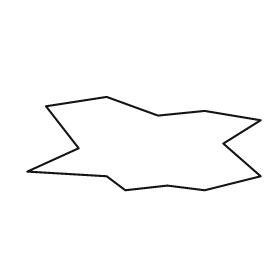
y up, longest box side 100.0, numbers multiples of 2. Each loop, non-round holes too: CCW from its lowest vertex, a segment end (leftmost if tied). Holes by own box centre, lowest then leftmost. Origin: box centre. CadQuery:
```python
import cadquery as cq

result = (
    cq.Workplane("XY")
    .moveTo(-8.0, -20.0)
    .lineTo(10.0, -18.0)
    .lineTo(26.0, -20.0)
    .lineTo(50.0, -14.0)
    .lineTo(34.0, 0.0)
    .lineTo(50.0, 10.0)
    .lineTo(26.0, 14.0)
    .lineTo(6.0, 12.0)
    .lineTo(-16.0, 20.0)
    .lineTo(-42.0, 16.0)
    .lineTo(-28.0, -2.0)
    .lineTo(-50.0, -12.0)
    .lineTo(-16.0, -14.0)
    .close()
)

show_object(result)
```